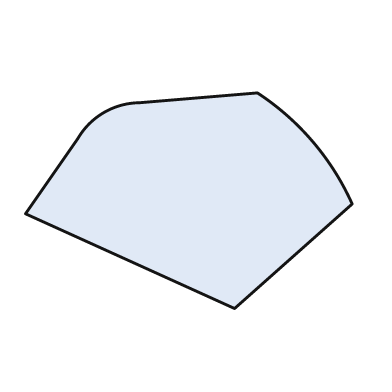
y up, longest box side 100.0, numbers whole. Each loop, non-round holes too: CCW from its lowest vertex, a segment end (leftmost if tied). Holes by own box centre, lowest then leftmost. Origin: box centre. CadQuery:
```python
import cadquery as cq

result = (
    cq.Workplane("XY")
    .moveTo(14.0, -33.0)
    .lineTo(50.0, -1.0)
    .threePointArc((38.0, 18.0), (21.0, 33.0))
    .lineTo(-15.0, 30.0)
    .threePointArc((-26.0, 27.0), (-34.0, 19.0))
    .lineTo(-50.0, -4.0)
    .close()
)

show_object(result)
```